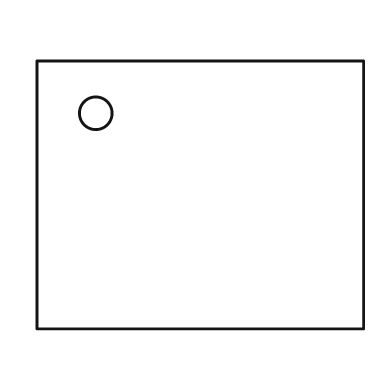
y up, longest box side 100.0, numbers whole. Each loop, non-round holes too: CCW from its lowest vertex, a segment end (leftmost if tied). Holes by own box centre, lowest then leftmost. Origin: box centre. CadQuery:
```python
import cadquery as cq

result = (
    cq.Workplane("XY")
    .moveTo(-50.0, -41.0)
    .lineTo(50.0, -41.0)
    .lineTo(50.0, 41.0)
    .lineTo(-50.0, 41.0)
    .close()
    .moveTo(-32.0, 25.0)
    .circle(5.0)
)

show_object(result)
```